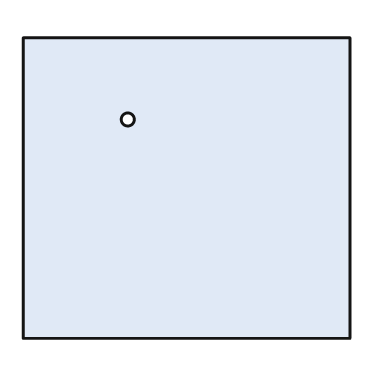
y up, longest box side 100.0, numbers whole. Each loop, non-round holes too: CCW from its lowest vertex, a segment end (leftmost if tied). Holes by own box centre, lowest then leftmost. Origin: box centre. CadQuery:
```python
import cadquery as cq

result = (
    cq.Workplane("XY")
    .moveTo(-50.0, -46.0)
    .lineTo(50.0, -46.0)
    .lineTo(50.0, 46.0)
    .lineTo(-50.0, 46.0)
    .close()
    .moveTo(-18.0, 21.0)
    .circle(2.0)
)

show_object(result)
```